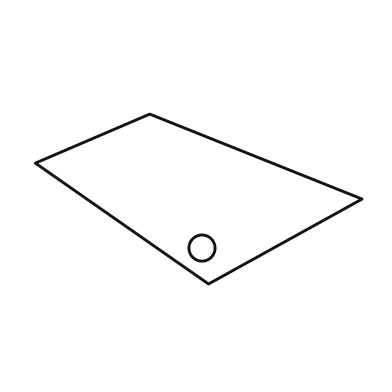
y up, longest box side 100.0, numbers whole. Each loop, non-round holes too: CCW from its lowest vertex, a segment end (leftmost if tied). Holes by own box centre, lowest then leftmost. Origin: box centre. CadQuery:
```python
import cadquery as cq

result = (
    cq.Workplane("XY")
    .moveTo(3.0, -26.0)
    .lineTo(50.0, 0.0)
    .lineTo(-15.0, 26.0)
    .lineTo(-50.0, 11.0)
    .close()
    .moveTo(1.0, -15.0)
    .circle(4.0)
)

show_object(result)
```